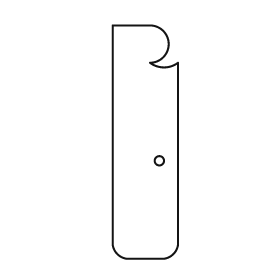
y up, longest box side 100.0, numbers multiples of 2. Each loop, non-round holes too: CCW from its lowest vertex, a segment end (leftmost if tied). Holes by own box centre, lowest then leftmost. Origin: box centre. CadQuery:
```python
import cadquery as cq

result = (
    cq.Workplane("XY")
    .moveTo(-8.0, -50.0)
    .lineTo(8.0, -50.0)
    .threePointArc((12.0, -48.0), (14.0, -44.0))
    .lineTo(14.0, 34.0)
    .threePointArc((8.0, 32.0), (2.0, 34.0))
    .threePointArc((10.0, 42.0), (2.0, 50.0))
    .lineTo(-14.0, 50.0)
    .lineTo(-14.0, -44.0)
    .threePointArc((-12.0, -48.0), (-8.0, -50.0))
    .close()
    .moveTo(6.0, -8.0)
    .circle(2.0)
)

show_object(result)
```